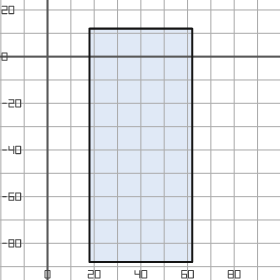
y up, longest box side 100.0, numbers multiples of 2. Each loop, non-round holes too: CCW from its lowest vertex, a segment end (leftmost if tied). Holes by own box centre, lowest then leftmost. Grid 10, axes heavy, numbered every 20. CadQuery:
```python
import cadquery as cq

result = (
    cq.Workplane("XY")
    .moveTo(18.0, -88.0)
    .lineTo(62.0, -88.0)
    .lineTo(62.0, 12.0)
    .lineTo(18.0, 12.0)
    .close()
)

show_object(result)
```